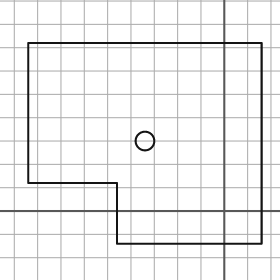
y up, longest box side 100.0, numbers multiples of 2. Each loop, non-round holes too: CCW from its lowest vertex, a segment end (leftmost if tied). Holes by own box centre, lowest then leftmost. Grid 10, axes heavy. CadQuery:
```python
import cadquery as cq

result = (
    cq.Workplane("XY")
    .moveTo(-46.0, -14.0)
    .lineTo(16.0, -14.0)
    .lineTo(16.0, 72.0)
    .lineTo(-84.0, 72.0)
    .lineTo(-84.0, 12.0)
    .lineTo(-46.0, 12.0)
    .close()
    .moveTo(-34.0, 30.0)
    .circle(4.0)
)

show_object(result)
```